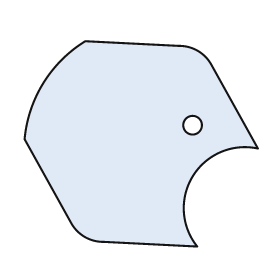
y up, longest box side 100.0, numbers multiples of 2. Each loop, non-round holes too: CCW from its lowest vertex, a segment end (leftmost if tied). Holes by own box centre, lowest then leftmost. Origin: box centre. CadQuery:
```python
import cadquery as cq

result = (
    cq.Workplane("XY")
    .moveTo(24.0, -44.0)
    .threePointArc((22.0, -14.0), (50.0, -2.0))
    .lineTo(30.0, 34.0)
    .threePointArc((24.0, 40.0), (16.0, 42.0))
    .lineTo(-24.0, 44.0)
    .threePointArc((-42.0, 26.0), (-50.0, 2.0))
    .lineTo(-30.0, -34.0)
    .threePointArc((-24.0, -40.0), (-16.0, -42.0))
    .close()
    .moveTo(22.0, 8.0)
    .circle(4.0)
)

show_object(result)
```